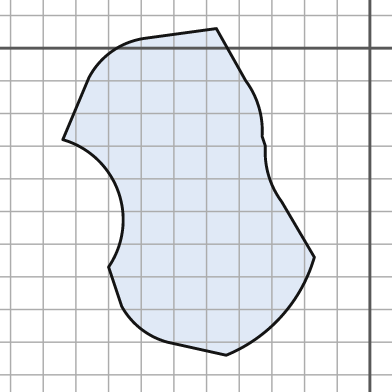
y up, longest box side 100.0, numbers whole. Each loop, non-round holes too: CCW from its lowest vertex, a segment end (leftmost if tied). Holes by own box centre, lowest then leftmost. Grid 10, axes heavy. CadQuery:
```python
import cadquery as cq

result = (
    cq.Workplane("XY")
    .moveTo(-44.0, -94.0)
    .threePointArc((-27.0, -82.0), (-17.0, -64.0))
    .lineTo(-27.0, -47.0)
    .threePointArc((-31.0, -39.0), (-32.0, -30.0))
    .lineTo(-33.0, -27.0)
    .threePointArc((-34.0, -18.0), (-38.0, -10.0))
    .lineTo(-47.0, 6.0)
    .lineTo(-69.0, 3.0)
    .threePointArc((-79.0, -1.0), (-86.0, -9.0))
    .lineTo(-94.0, -28.0)
    .threePointArc((-77.0, -44.0), (-80.0, -67.0))
    .lineTo(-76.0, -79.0)
    .threePointArc((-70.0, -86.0), (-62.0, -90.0))
    .close()
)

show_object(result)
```